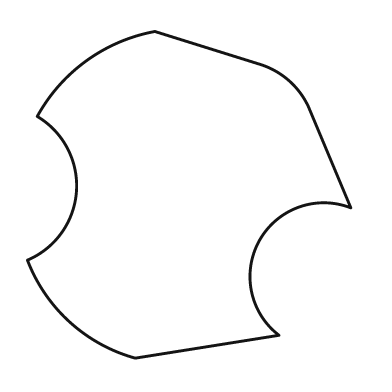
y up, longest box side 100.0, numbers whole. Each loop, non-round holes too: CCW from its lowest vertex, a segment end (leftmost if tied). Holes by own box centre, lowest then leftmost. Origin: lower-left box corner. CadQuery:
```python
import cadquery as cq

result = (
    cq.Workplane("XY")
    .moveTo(33.0, 0.0)
    .lineTo(77.0, 7.0)
    .threePointArc((71.0, 36.0), (99.0, 46.0))
    .lineTo(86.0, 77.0)
    .threePointArc((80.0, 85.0), (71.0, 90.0))
    .lineTo(39.0, 100.0)
    .threePointArc((18.0, 91.0), (3.0, 74.0))
    .threePointArc((15.0, 51.0), (0.0, 30.0))
    .threePointArc((13.0, 11.0), (33.0, 0.0))
    .close()
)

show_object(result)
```